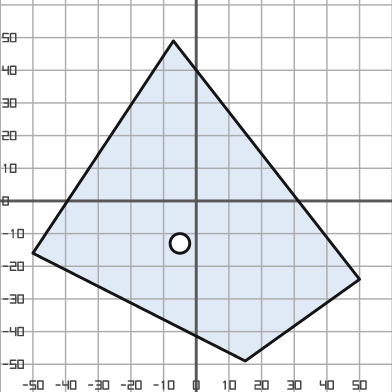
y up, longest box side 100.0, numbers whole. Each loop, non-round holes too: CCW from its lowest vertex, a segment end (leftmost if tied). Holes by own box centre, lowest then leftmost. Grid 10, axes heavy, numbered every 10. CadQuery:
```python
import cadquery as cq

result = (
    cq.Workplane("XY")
    .moveTo(15.0, -49.0)
    .lineTo(50.0, -24.0)
    .lineTo(-7.0, 49.0)
    .lineTo(-50.0, -16.0)
    .close()
    .moveTo(-5.0, -13.0)
    .circle(3.0)
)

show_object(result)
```